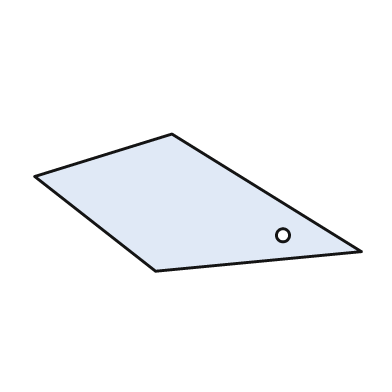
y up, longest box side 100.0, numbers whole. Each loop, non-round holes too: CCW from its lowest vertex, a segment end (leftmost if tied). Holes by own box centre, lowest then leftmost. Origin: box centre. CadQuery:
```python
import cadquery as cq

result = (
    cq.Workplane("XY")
    .moveTo(-13.0, -21.0)
    .lineTo(50.0, -15.0)
    .lineTo(-8.0, 21.0)
    .lineTo(-50.0, 8.0)
    .close()
    .moveTo(26.0, -10.0)
    .circle(2.0)
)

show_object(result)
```